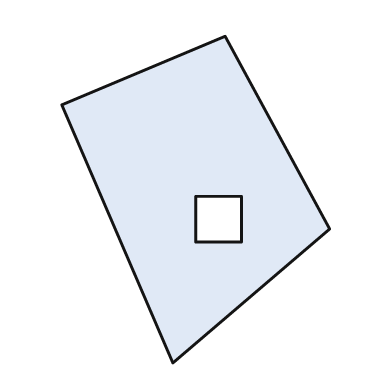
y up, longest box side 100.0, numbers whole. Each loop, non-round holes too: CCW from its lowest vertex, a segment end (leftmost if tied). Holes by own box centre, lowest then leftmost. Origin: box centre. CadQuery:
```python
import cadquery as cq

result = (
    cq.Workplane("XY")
    .moveTo(-7.0, -50.0)
    .lineTo(41.0, -9.0)
    .lineTo(9.0, 50.0)
    .lineTo(-41.0, 29.0)
    .close()
    .moveTo(0.0, -13.0)
    .lineTo(14.0, -13.0)
    .lineTo(14.0, 1.0)
    .lineTo(0.0, 1.0)
    .close()
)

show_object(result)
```